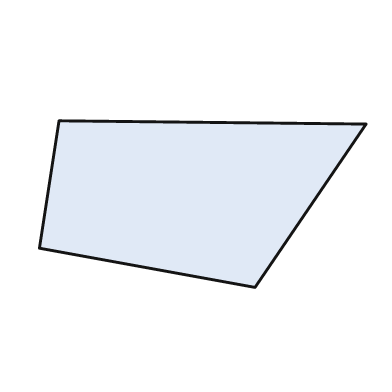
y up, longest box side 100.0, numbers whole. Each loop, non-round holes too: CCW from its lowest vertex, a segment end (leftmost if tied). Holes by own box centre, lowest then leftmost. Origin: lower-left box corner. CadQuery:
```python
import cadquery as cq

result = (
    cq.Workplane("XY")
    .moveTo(66.0, 0.0)
    .lineTo(100.0, 50.0)
    .lineTo(6.0, 51.0)
    .lineTo(0.0, 12.0)
    .close()
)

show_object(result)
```